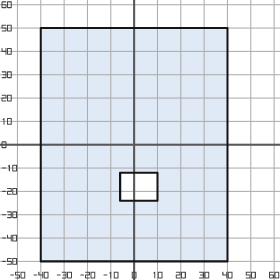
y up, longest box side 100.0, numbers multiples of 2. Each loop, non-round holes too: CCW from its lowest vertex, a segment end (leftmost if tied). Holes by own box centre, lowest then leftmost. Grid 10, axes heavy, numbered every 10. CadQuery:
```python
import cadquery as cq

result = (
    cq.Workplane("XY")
    .moveTo(-40.0, -50.0)
    .lineTo(40.0, -50.0)
    .lineTo(40.0, 50.0)
    .lineTo(-40.0, 50.0)
    .close()
    .moveTo(-6.0, -24.0)
    .lineTo(10.0, -24.0)
    .lineTo(10.0, -12.0)
    .lineTo(-6.0, -12.0)
    .close()
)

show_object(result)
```